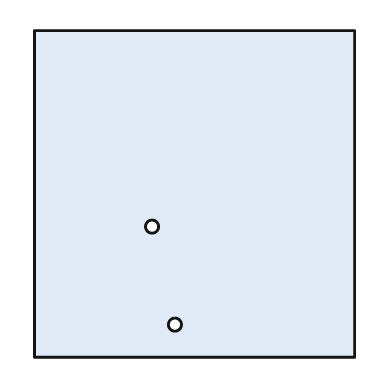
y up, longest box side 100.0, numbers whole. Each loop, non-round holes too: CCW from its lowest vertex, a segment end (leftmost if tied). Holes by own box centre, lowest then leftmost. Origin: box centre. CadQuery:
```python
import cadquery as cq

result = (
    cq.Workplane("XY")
    .moveTo(-49.0, -50.0)
    .lineTo(49.0, -50.0)
    .lineTo(49.0, 50.0)
    .lineTo(-49.0, 50.0)
    .close()
    .moveTo(-6.0, -40.0)
    .circle(2.0)
    .moveTo(-13.0, -10.0)
    .circle(2.0)
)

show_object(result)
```